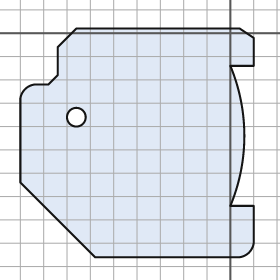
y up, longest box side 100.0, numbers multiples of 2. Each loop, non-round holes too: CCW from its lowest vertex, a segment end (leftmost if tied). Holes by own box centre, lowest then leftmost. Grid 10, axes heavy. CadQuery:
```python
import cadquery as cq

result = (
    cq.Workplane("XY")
    .moveTo(-58.0, -96.0)
    .lineTo(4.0, -96.0)
    .threePointArc((8.0, -94.0), (10.0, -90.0))
    .lineTo(10.0, -74.0)
    .lineTo(0.0, -74.0)
    .threePointArc((6.0, -44.0), (0.0, -14.0))
    .lineTo(10.0, -14.0)
    .lineTo(10.0, -2.0)
    .lineTo(4.0, 2.0)
    .lineTo(-66.0, 2.0)
    .lineTo(-74.0, -6.0)
    .lineTo(-74.0, -18.0)
    .lineTo(-78.0, -22.0)
    .lineTo(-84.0, -22.0)
    .threePointArc((-88.0, -24.0), (-90.0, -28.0))
    .lineTo(-90.0, -64.0)
    .close()
    .moveTo(-66.0, -36.0)
    .circle(4.0)
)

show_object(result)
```